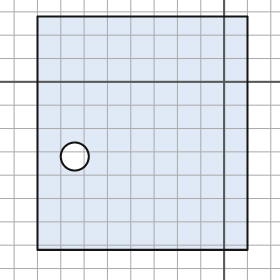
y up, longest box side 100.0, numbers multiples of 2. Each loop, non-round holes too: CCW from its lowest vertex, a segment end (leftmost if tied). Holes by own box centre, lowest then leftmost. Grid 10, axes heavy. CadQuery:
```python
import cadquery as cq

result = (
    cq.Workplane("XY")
    .moveTo(-80.0, -72.0)
    .lineTo(10.0, -72.0)
    .lineTo(10.0, 28.0)
    .lineTo(-80.0, 28.0)
    .close()
    .moveTo(-64.0, -32.0)
    .circle(6.0)
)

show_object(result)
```